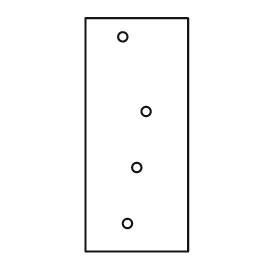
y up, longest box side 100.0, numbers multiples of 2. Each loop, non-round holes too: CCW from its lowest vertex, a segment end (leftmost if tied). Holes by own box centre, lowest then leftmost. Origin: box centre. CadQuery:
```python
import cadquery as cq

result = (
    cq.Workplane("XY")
    .moveTo(-22.0, -50.0)
    .lineTo(22.0, -50.0)
    .lineTo(22.0, 50.0)
    .lineTo(-22.0, 50.0)
    .close()
    .moveTo(-4.0, -38.0)
    .circle(2.0)
    .moveTo(0.0, -14.0)
    .circle(2.0)
    .moveTo(4.0, 10.0)
    .circle(2.0)
    .moveTo(-6.0, 42.0)
    .circle(2.0)
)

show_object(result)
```